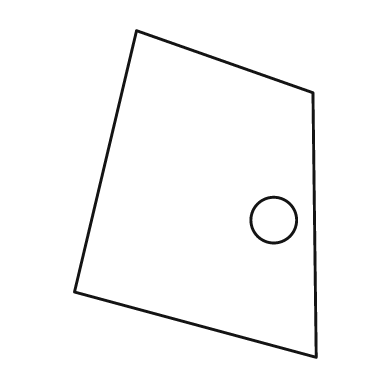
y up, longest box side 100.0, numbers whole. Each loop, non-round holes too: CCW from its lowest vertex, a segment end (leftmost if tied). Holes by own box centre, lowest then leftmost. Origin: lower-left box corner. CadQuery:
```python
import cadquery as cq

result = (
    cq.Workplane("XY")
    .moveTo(74.0, 0.0)
    .lineTo(73.0, 81.0)
    .lineTo(19.0, 100.0)
    .lineTo(0.0, 20.0)
    .close()
    .moveTo(61.0, 42.0)
    .circle(7.0)
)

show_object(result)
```